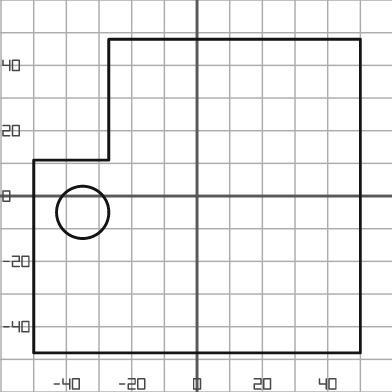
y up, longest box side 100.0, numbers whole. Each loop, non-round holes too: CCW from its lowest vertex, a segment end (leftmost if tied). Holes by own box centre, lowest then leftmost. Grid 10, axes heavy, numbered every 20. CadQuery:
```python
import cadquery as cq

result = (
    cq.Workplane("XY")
    .moveTo(-50.0, -48.0)
    .lineTo(50.0, -48.0)
    .lineTo(50.0, 48.0)
    .lineTo(-27.0, 48.0)
    .lineTo(-27.0, 11.0)
    .lineTo(-50.0, 11.0)
    .close()
    .moveTo(-35.0, -5.0)
    .circle(8.0)
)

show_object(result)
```